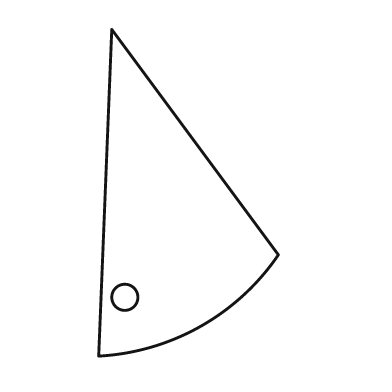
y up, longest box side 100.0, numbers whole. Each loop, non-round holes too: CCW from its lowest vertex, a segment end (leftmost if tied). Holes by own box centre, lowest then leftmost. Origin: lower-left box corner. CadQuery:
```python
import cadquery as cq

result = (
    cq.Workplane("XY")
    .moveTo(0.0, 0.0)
    .threePointArc((31.0, 9.0), (55.0, 31.0))
    .lineTo(4.0, 100.0)
    .close()
    .moveTo(8.0, 18.0)
    .circle(4.0)
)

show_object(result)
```